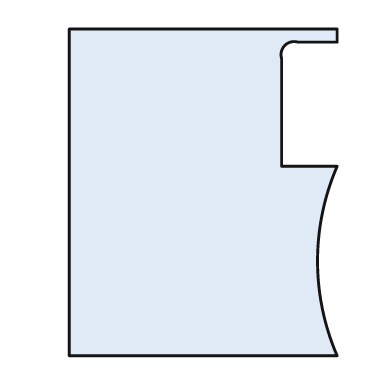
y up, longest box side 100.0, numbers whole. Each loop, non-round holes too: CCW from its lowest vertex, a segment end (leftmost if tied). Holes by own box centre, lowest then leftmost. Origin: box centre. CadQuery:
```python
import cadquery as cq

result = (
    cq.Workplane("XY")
    .moveTo(-41.0, -50.0)
    .lineTo(41.0, -50.0)
    .threePointArc((35.0, -21.0), (41.0, 8.0))
    .lineTo(24.0, 8.0)
    .lineTo(24.0, 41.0)
    .threePointArc((25.0, 45.0), (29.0, 46.0))
    .lineTo(41.0, 46.0)
    .lineTo(41.0, 50.0)
    .lineTo(-41.0, 50.0)
    .close()
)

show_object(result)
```